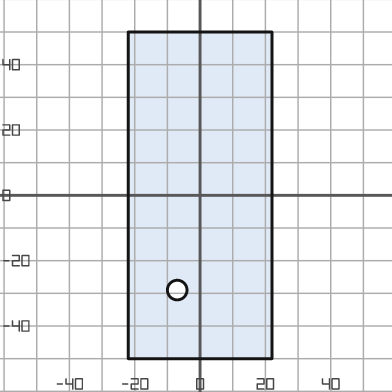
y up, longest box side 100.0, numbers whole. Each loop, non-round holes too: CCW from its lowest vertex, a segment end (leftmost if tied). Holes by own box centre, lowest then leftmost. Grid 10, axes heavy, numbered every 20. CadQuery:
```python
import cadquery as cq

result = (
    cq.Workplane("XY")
    .moveTo(-22.0, -50.0)
    .lineTo(22.0, -50.0)
    .lineTo(22.0, 50.0)
    .lineTo(-22.0, 50.0)
    .close()
    .moveTo(-7.0, -29.0)
    .circle(3.0)
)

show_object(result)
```